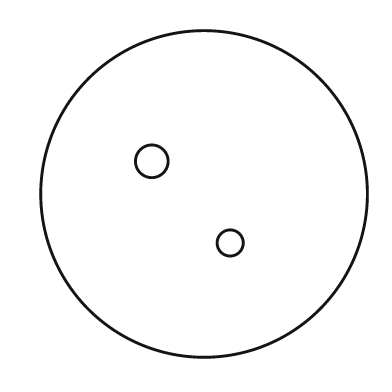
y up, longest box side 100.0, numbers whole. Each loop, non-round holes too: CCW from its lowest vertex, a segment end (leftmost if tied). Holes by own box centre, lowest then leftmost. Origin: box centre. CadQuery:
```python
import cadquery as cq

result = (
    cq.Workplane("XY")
    .moveTo(0.0, 0.0)
    .circle(50.0)
    .moveTo(8.0, -15.0)
    .circle(4.0)
    .moveTo(-16.0, 10.0)
    .circle(5.0)
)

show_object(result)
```